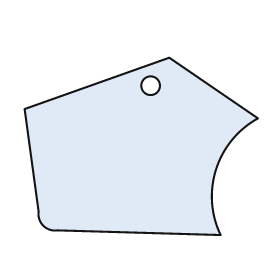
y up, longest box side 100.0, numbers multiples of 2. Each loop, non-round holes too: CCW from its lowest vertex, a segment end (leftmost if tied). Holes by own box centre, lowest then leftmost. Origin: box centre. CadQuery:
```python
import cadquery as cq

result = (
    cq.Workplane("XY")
    .moveTo(34.0, -38.0)
    .threePointArc((32.0, -10.0), (50.0, 12.0))
    .lineTo(12.0, 38.0)
    .lineTo(-50.0, 16.0)
    .lineTo(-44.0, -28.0)
    .threePointArc((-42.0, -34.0), (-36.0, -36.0))
    .close()
    .moveTo(4.0, 26.0)
    .circle(4.0)
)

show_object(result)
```